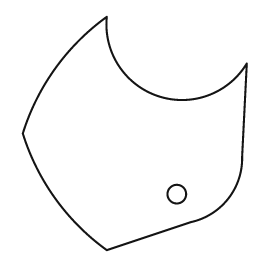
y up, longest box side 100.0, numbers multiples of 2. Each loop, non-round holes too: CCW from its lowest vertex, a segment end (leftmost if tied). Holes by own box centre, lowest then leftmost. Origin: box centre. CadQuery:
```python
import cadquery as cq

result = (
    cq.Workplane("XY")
    .moveTo(-12.0, -50.0)
    .lineTo(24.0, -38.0)
    .threePointArc((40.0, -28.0), (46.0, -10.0))
    .lineTo(48.0, 30.0)
    .threePointArc((10.0, 16.0), (-12.0, 50.0))
    .threePointArc((-34.0, 28.0), (-48.0, 0.0))
    .threePointArc((-34.0, -28.0), (-12.0, -50.0))
    .close()
    .moveTo(18.0, -26.0)
    .circle(4.0)
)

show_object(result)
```